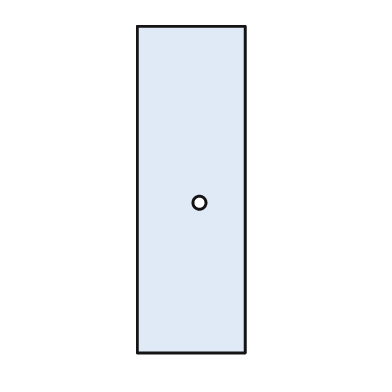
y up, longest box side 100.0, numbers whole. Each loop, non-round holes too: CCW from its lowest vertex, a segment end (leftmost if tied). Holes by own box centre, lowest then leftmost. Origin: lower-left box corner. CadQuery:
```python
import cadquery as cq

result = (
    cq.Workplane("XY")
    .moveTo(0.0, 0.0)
    .lineTo(33.0, 0.0)
    .lineTo(33.0, 100.0)
    .lineTo(0.0, 100.0)
    .close()
    .moveTo(19.0, 46.0)
    .circle(2.0)
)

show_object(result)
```